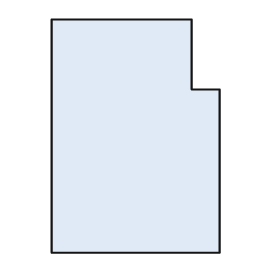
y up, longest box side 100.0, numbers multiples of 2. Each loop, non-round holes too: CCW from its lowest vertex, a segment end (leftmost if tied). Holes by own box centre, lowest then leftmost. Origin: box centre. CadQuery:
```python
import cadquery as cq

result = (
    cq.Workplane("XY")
    .moveTo(-36.0, -50.0)
    .lineTo(36.0, -50.0)
    .lineTo(36.0, 20.0)
    .lineTo(24.0, 20.0)
    .lineTo(24.0, 50.0)
    .lineTo(-36.0, 50.0)
    .close()
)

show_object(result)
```